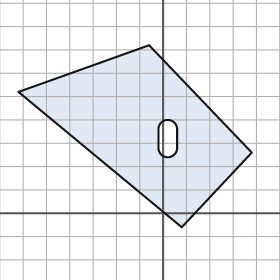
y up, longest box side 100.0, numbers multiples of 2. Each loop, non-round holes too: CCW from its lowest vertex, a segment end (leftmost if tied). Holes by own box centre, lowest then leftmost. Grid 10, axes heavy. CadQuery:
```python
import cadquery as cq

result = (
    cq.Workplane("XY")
    .moveTo(8.0, -6.0)
    .lineTo(38.0, 26.0)
    .lineTo(-6.0, 72.0)
    .lineTo(-62.0, 52.0)
    .close()
    .moveTo(-2.0, 28.0)
    .threePointArc((2.0, 24.0), (6.0, 28.0))
    .lineTo(6.0, 36.0)
    .threePointArc((2.0, 40.0), (-2.0, 36.0))
    .close()
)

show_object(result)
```